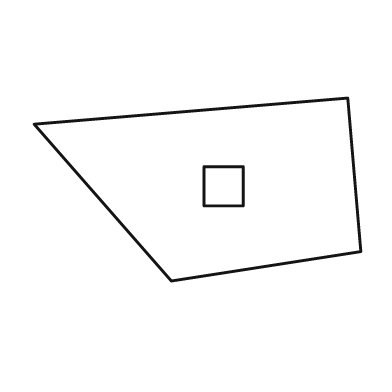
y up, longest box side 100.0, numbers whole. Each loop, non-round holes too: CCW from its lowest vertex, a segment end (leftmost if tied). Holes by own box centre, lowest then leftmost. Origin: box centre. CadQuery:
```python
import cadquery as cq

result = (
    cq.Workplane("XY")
    .moveTo(-8.0, -28.0)
    .lineTo(50.0, -19.0)
    .lineTo(46.0, 28.0)
    .lineTo(-50.0, 20.0)
    .close()
    .moveTo(2.0, -5.0)
    .lineTo(14.0, -5.0)
    .lineTo(14.0, 7.0)
    .lineTo(2.0, 7.0)
    .close()
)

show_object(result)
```